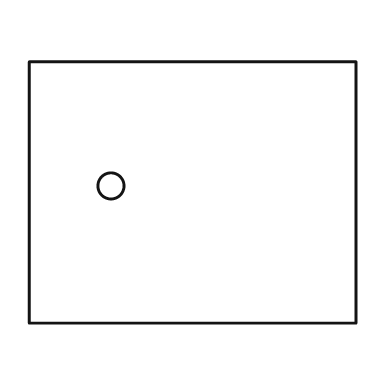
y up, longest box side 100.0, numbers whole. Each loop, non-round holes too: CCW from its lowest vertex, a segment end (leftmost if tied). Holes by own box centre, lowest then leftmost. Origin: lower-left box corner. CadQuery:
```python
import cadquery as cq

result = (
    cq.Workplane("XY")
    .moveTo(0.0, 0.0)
    .lineTo(100.0, 0.0)
    .lineTo(100.0, 80.0)
    .lineTo(0.0, 80.0)
    .close()
    .moveTo(25.0, 42.0)
    .circle(4.0)
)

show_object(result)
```